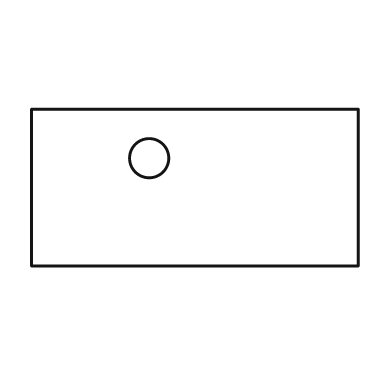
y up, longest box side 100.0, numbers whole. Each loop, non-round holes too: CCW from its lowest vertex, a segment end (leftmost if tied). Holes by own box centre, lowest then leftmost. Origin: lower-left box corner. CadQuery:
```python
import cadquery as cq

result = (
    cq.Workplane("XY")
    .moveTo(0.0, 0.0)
    .lineTo(100.0, 0.0)
    .lineTo(100.0, 48.0)
    .lineTo(0.0, 48.0)
    .close()
    .moveTo(36.0, 33.0)
    .circle(6.0)
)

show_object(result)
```